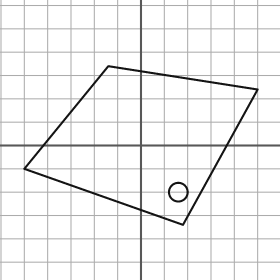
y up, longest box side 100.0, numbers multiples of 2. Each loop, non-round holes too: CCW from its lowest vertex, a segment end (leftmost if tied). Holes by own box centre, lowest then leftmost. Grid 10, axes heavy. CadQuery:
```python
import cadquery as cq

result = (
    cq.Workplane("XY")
    .moveTo(18.0, -34.0)
    .lineTo(50.0, 24.0)
    .lineTo(-14.0, 34.0)
    .lineTo(-50.0, -10.0)
    .close()
    .moveTo(16.0, -20.0)
    .circle(4.0)
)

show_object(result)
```